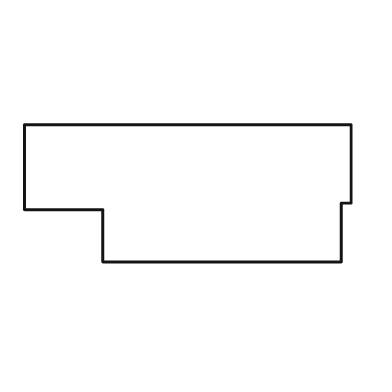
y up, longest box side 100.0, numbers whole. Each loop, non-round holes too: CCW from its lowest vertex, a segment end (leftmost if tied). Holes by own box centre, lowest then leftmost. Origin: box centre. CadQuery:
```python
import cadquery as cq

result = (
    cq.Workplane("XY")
    .moveTo(-26.0, -21.0)
    .lineTo(47.0, -21.0)
    .lineTo(47.0, -3.0)
    .lineTo(50.0, -3.0)
    .lineTo(50.0, 21.0)
    .lineTo(-50.0, 21.0)
    .lineTo(-50.0, -5.0)
    .lineTo(-26.0, -5.0)
    .close()
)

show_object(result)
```